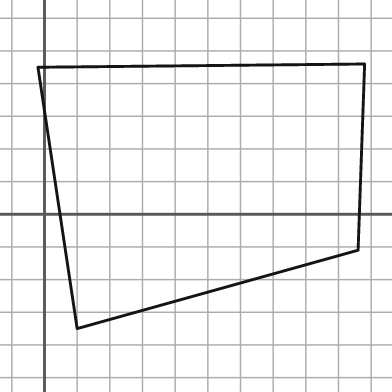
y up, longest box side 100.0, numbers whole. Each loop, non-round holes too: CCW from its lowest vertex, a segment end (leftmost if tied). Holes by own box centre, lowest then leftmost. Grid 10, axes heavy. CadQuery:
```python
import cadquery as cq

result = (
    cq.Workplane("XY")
    .moveTo(10.0, -35.0)
    .lineTo(96.0, -11.0)
    .lineTo(98.0, 46.0)
    .lineTo(-2.0, 45.0)
    .close()
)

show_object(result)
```